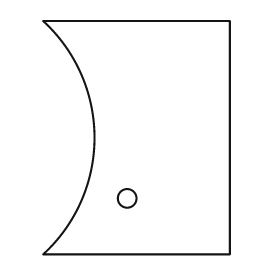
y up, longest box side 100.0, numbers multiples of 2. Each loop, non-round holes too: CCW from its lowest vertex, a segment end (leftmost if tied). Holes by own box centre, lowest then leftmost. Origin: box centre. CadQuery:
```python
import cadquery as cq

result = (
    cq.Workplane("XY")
    .moveTo(-40.0, -50.0)
    .lineTo(40.0, -50.0)
    .lineTo(40.0, 50.0)
    .lineTo(-40.0, 50.0)
    .threePointArc((-18.0, 0.0), (-40.0, -50.0))
    .close()
    .moveTo(-4.0, -26.0)
    .circle(4.0)
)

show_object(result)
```